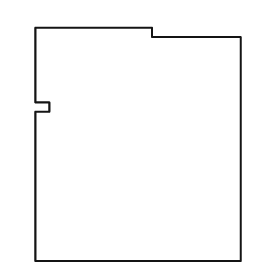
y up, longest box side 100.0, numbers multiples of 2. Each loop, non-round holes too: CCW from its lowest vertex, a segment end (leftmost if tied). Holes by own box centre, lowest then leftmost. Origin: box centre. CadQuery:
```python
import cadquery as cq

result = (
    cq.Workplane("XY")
    .moveTo(-44.0, -50.0)
    .lineTo(44.0, -50.0)
    .lineTo(44.0, 46.0)
    .lineTo(6.0, 46.0)
    .lineTo(6.0, 50.0)
    .lineTo(-44.0, 50.0)
    .lineTo(-44.0, 18.0)
    .lineTo(-38.0, 18.0)
    .lineTo(-38.0, 14.0)
    .lineTo(-44.0, 14.0)
    .close()
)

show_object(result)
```